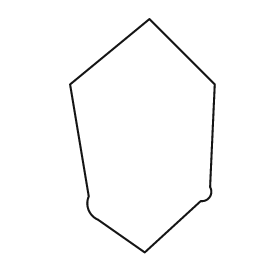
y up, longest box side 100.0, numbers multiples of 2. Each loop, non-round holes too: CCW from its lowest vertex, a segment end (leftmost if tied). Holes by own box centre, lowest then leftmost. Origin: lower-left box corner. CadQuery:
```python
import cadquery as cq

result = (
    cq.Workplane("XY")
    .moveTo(32.0, 0.0)
    .lineTo(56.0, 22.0)
    .threePointArc((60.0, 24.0), (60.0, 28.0))
    .lineTo(62.0, 72.0)
    .lineTo(34.0, 100.0)
    .lineTo(0.0, 72.0)
    .lineTo(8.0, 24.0)
    .threePointArc((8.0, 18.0), (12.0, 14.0))
    .close()
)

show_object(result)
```